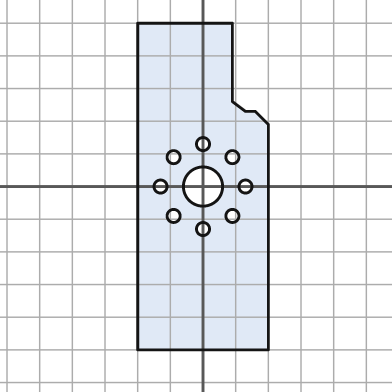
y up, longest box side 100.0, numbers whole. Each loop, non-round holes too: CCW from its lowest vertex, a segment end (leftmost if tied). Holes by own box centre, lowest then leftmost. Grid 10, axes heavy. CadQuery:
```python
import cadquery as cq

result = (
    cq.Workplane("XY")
    .moveTo(-20.0, -50.0)
    .lineTo(20.0, -50.0)
    .lineTo(20.0, 19.0)
    .lineTo(16.0, 23.0)
    .lineTo(13.0, 23.0)
    .lineTo(9.0, 26.0)
    .lineTo(9.0, 50.0)
    .lineTo(-20.0, 50.0)
    .close()
    .moveTo(0.0, -13.0)
    .circle(2.0)
    .moveTo(-9.0, -9.0)
    .circle(2.0)
    .moveTo(9.0, -9.0)
    .circle(2.0)
    .moveTo(-13.0, 0.0)
    .circle(2.0)
    .moveTo(0.0, 0.0)
    .circle(6.0)
    .moveTo(13.0, 0.0)
    .circle(2.0)
    .moveTo(-9.0, 9.0)
    .circle(2.0)
    .moveTo(9.0, 9.0)
    .circle(2.0)
    .moveTo(0.0, 13.0)
    .circle(2.0)
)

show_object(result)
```